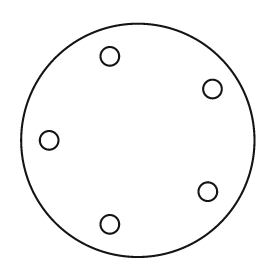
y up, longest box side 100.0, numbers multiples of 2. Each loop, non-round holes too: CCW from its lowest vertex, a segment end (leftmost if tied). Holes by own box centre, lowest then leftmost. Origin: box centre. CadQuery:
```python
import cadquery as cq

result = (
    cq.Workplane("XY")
    .moveTo(0.0, 0.0)
    .circle(50.0)
    .moveTo(-12.0, -36.0)
    .circle(4.0)
    .moveTo(30.0, -22.0)
    .circle(4.0)
    .moveTo(-38.0, 0.0)
    .circle(4.0)
    .moveTo(32.0, 22.0)
    .circle(4.0)
    .moveTo(-12.0, 36.0)
    .circle(4.0)
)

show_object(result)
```